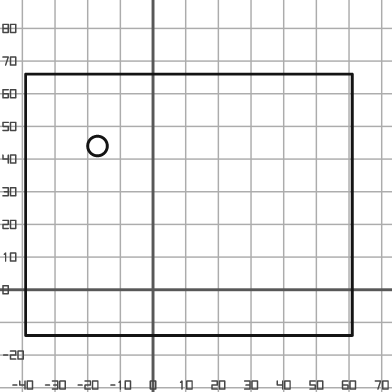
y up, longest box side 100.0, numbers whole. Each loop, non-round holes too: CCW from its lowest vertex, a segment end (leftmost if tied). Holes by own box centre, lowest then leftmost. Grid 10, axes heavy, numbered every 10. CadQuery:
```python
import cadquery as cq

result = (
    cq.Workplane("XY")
    .moveTo(-39.0, -14.0)
    .lineTo(61.0, -14.0)
    .lineTo(61.0, 66.0)
    .lineTo(-39.0, 66.0)
    .close()
    .moveTo(-17.0, 44.0)
    .circle(3.0)
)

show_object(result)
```